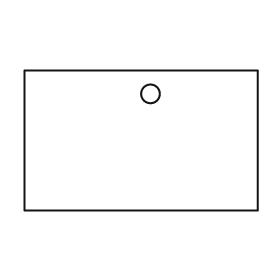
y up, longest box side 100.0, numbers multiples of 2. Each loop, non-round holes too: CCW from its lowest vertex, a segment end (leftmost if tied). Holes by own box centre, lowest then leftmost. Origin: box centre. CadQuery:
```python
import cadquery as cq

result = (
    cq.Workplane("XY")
    .moveTo(-50.0, -30.0)
    .lineTo(50.0, -30.0)
    .lineTo(50.0, 30.0)
    .lineTo(-50.0, 30.0)
    .close()
    .moveTo(4.0, 20.0)
    .circle(4.0)
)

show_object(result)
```